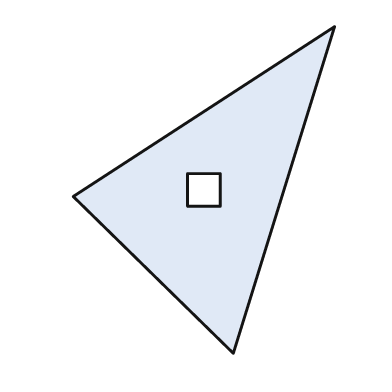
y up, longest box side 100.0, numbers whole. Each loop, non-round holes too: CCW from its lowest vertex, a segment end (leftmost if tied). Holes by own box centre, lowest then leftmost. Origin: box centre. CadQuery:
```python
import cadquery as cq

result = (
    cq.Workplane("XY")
    .moveTo(9.0, -50.0)
    .lineTo(40.0, 50.0)
    .lineTo(-40.0, -2.0)
    .close()
    .moveTo(-5.0, -5.0)
    .lineTo(5.0, -5.0)
    .lineTo(5.0, 5.0)
    .lineTo(-5.0, 5.0)
    .close()
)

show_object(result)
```